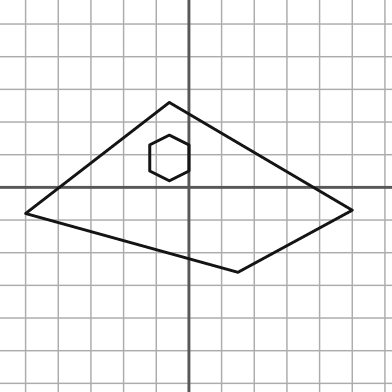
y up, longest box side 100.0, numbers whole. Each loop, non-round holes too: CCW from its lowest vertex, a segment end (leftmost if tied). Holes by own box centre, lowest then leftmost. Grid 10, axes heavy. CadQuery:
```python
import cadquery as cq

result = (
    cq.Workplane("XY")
    .moveTo(15.0, -26.0)
    .lineTo(50.0, -7.0)
    .lineTo(-6.0, 26.0)
    .lineTo(-50.0, -8.0)
    .close()
    .moveTo(-6.0, 2.0)
    .lineTo(0.0, 5.0)
    .lineTo(0.0, 13.0)
    .lineTo(-6.0, 16.0)
    .lineTo(-12.0, 13.0)
    .lineTo(-12.0, 5.0)
    .close()
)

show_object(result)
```